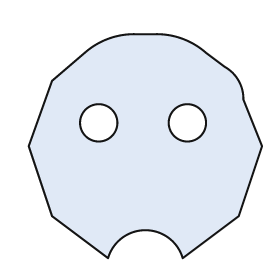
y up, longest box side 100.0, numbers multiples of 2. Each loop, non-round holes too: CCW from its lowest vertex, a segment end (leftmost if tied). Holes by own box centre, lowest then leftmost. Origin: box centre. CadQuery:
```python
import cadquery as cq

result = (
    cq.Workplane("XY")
    .moveTo(-16.0, -48.0)
    .threePointArc((0.0, -36.0), (16.0, -48.0))
    .lineTo(40.0, -30.0)
    .lineTo(50.0, 0.0)
    .lineTo(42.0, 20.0)
    .threePointArc((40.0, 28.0), (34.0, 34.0))
    .lineTo(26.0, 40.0)
    .threePointArc((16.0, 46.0), (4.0, 48.0))
    .lineTo(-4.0, 48.0)
    .threePointArc((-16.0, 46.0), (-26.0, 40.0))
    .lineTo(-40.0, 28.0)
    .lineTo(-50.0, 0.0)
    .lineTo(-40.0, -30.0)
    .close()
    .moveTo(-20.0, 10.0)
    .circle(8.0)
    .moveTo(18.0, 10.0)
    .circle(8.0)
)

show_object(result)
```